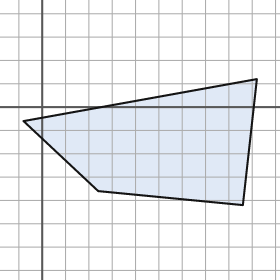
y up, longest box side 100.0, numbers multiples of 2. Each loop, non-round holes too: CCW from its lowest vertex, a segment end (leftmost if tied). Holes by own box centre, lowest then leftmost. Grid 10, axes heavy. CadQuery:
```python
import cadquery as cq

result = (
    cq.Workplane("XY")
    .moveTo(86.0, -42.0)
    .lineTo(92.0, 12.0)
    .lineTo(-8.0, -6.0)
    .lineTo(24.0, -36.0)
    .close()
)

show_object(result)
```